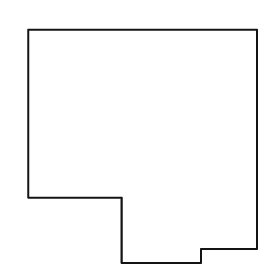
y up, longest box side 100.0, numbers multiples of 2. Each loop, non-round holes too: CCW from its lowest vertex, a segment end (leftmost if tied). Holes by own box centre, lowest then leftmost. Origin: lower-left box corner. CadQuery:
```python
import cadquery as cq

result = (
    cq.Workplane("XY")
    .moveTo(40.0, 0.0)
    .lineTo(74.0, 0.0)
    .lineTo(74.0, 6.0)
    .lineTo(98.0, 6.0)
    .lineTo(98.0, 100.0)
    .lineTo(0.0, 100.0)
    .lineTo(0.0, 28.0)
    .lineTo(40.0, 28.0)
    .close()
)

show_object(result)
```